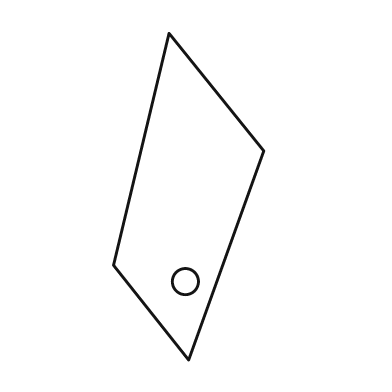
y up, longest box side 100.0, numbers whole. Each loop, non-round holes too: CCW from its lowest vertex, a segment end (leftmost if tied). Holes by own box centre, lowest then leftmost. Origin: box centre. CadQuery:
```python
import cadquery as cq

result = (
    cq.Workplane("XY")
    .moveTo(0.0, -50.0)
    .lineTo(23.0, 14.0)
    .lineTo(-6.0, 50.0)
    .lineTo(-23.0, -21.0)
    .close()
    .moveTo(-1.0, -26.0)
    .circle(4.0)
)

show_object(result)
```